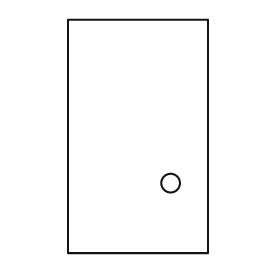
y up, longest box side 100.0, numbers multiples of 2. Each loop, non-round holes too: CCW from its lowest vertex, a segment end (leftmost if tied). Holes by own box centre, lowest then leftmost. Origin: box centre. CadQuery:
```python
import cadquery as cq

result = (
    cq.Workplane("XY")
    .moveTo(-30.0, -50.0)
    .lineTo(30.0, -50.0)
    .lineTo(30.0, 50.0)
    .lineTo(-30.0, 50.0)
    .close()
    .moveTo(14.0, -20.0)
    .circle(4.0)
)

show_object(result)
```